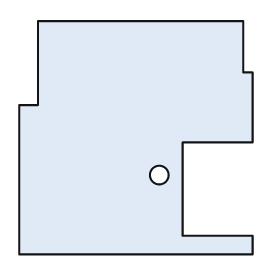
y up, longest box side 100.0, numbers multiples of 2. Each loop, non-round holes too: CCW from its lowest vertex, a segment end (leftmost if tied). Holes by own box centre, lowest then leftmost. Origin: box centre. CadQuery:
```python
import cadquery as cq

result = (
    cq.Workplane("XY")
    .moveTo(-50.0, -50.0)
    .lineTo(50.0, -50.0)
    .lineTo(50.0, -42.0)
    .lineTo(20.0, -42.0)
    .lineTo(20.0, -2.0)
    .lineTo(50.0, -2.0)
    .lineTo(50.0, 28.0)
    .lineTo(46.0, 28.0)
    .lineTo(46.0, 50.0)
    .lineTo(-42.0, 50.0)
    .lineTo(-42.0, 14.0)
    .lineTo(-50.0, 14.0)
    .close()
    .moveTo(10.0, -16.0)
    .circle(4.0)
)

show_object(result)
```